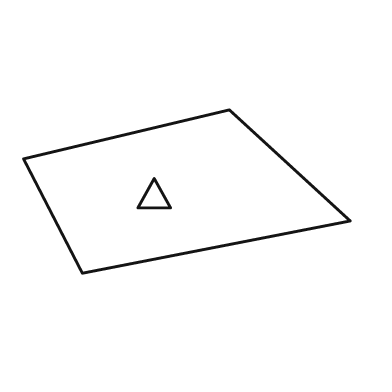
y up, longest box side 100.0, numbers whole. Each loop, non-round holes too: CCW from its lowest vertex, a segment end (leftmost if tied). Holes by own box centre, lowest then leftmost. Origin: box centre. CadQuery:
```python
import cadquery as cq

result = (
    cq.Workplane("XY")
    .moveTo(-32.0, -25.0)
    .lineTo(50.0, -9.0)
    .lineTo(13.0, 25.0)
    .lineTo(-50.0, 10.0)
    .close()
    .moveTo(-15.0, -5.0)
    .lineTo(-5.0, -5.0)
    .lineTo(-10.0, 4.0)
    .close()
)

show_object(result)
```